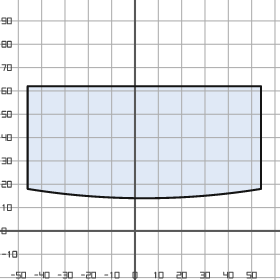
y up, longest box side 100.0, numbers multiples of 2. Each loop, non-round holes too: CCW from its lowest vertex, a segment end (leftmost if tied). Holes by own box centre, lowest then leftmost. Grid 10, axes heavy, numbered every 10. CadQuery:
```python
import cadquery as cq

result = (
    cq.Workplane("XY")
    .moveTo(-46.0, 18.0)
    .threePointArc((4.0, 14.0), (54.0, 18.0))
    .lineTo(54.0, 62.0)
    .lineTo(-46.0, 62.0)
    .close()
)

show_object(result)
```